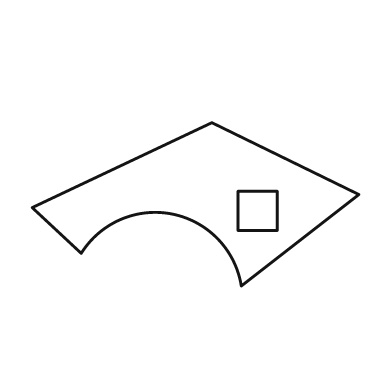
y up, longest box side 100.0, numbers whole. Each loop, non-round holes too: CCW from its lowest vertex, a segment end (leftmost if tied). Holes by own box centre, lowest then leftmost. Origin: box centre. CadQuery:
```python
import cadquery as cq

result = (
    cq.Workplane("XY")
    .moveTo(14.0, -25.0)
    .lineTo(50.0, 3.0)
    .lineTo(5.0, 25.0)
    .lineTo(-50.0, -1.0)
    .lineTo(-35.0, -15.0)
    .threePointArc((-7.0, -3.0), (14.0, -25.0))
    .close()
    .moveTo(13.0, -8.0)
    .lineTo(25.0, -8.0)
    .lineTo(25.0, 4.0)
    .lineTo(13.0, 4.0)
    .close()
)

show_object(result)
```